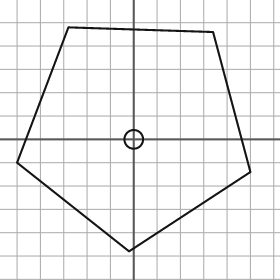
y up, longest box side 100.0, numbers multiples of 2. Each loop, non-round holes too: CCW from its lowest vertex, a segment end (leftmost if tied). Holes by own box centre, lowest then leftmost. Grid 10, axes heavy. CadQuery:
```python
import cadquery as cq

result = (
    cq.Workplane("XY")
    .moveTo(-2.0, -48.0)
    .lineTo(50.0, -14.0)
    .lineTo(34.0, 46.0)
    .lineTo(-28.0, 48.0)
    .lineTo(-50.0, -10.0)
    .close()
    .moveTo(0.0, 0.0)
    .circle(4.0)
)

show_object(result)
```